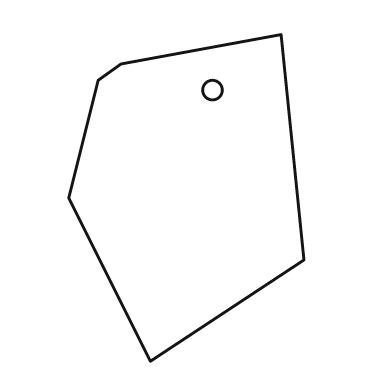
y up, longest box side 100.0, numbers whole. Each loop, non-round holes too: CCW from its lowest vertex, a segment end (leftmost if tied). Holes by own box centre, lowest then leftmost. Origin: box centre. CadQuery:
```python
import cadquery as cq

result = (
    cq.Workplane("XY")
    .moveTo(-11.0, -50.0)
    .lineTo(36.0, -19.0)
    .lineTo(29.0, 50.0)
    .lineTo(-20.0, 41.0)
    .lineTo(-27.0, 36.0)
    .lineTo(-36.0, 0.0)
    .close()
    .moveTo(8.0, 33.0)
    .circle(3.0)
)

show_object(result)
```